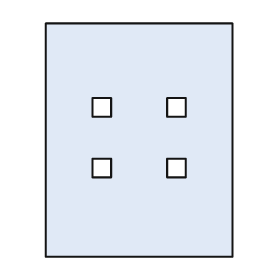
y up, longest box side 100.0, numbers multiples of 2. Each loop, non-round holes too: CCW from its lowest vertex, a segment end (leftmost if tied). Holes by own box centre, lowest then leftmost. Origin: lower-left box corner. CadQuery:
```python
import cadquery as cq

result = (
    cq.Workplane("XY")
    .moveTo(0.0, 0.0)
    .lineTo(80.0, 0.0)
    .lineTo(80.0, 100.0)
    .lineTo(0.0, 100.0)
    .close()
    .moveTo(20.0, 34.0)
    .lineTo(28.0, 34.0)
    .lineTo(28.0, 42.0)
    .lineTo(20.0, 42.0)
    .close()
    .moveTo(52.0, 34.0)
    .lineTo(60.0, 34.0)
    .lineTo(60.0, 42.0)
    .lineTo(52.0, 42.0)
    .close()
    .moveTo(20.0, 60.0)
    .lineTo(28.0, 60.0)
    .lineTo(28.0, 68.0)
    .lineTo(20.0, 68.0)
    .close()
    .moveTo(52.0, 60.0)
    .lineTo(60.0, 60.0)
    .lineTo(60.0, 68.0)
    .lineTo(52.0, 68.0)
    .close()
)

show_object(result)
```